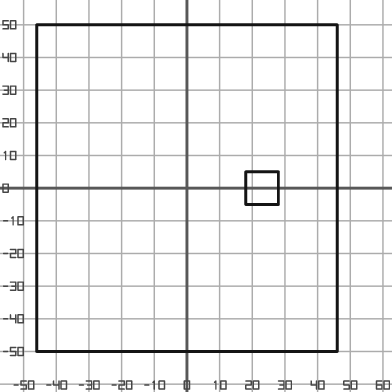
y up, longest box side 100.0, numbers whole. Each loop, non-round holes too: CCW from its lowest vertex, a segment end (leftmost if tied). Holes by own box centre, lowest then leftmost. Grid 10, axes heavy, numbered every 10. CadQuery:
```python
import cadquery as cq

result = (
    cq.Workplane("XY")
    .moveTo(-46.0, -50.0)
    .lineTo(46.0, -50.0)
    .lineTo(46.0, 50.0)
    .lineTo(-46.0, 50.0)
    .close()
    .moveTo(18.0, -5.0)
    .lineTo(28.0, -5.0)
    .lineTo(28.0, 5.0)
    .lineTo(18.0, 5.0)
    .close()
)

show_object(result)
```